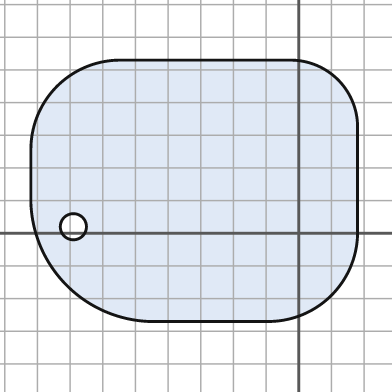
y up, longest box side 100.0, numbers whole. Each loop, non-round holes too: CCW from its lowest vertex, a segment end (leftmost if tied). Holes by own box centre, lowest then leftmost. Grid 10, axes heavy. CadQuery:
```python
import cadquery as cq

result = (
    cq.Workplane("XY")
    .moveTo(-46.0, -27.0)
    .lineTo(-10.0, -27.0)
    .threePointArc((10.0, -19.0), (18.0, 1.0))
    .lineTo(18.0, 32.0)
    .threePointArc((12.0, 47.0), (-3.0, 53.0))
    .lineTo(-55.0, 53.0)
    .threePointArc((-74.0, 45.0), (-82.0, 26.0))
    .lineTo(-82.0, 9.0)
    .threePointArc((-71.0, -16.0), (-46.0, -27.0))
    .close()
    .moveTo(-69.0, 2.0)
    .circle(4.0)
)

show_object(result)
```